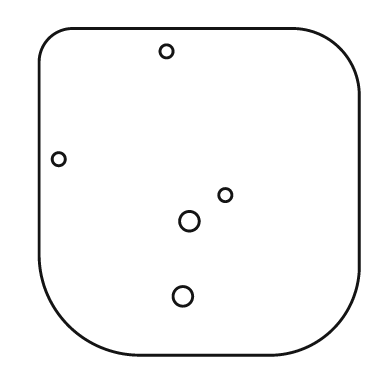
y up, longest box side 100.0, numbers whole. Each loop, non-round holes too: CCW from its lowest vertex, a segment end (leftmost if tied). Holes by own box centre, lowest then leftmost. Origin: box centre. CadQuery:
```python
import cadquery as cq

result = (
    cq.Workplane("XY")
    .moveTo(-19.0, -50.0)
    .lineTo(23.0, -50.0)
    .threePointArc((41.0, -42.0), (49.0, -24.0))
    .lineTo(49.0, 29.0)
    .threePointArc((43.0, 44.0), (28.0, 50.0))
    .lineTo(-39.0, 50.0)
    .threePointArc((-46.0, 47.0), (-49.0, 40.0))
    .lineTo(-49.0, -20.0)
    .threePointArc((-40.0, -41.0), (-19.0, -50.0))
    .close()
    .moveTo(-5.0, -32.0)
    .circle(3.0)
    .moveTo(-3.0, -9.0)
    .circle(3.0)
    .moveTo(8.0, -1.0)
    .circle(2.0)
    .moveTo(-43.0, 10.0)
    .circle(2.0)
    .moveTo(-10.0, 43.0)
    .circle(2.0)
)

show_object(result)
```